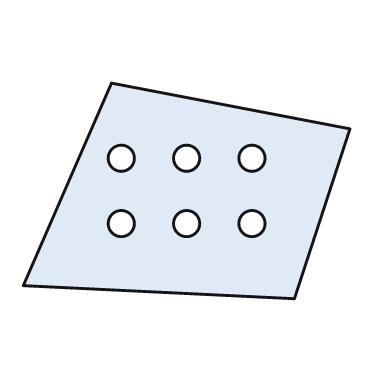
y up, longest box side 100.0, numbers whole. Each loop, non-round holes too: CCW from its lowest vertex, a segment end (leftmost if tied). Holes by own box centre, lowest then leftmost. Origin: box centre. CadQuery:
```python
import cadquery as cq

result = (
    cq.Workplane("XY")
    .moveTo(33.0, -33.0)
    .lineTo(50.0, 19.0)
    .lineTo(-23.0, 33.0)
    .lineTo(-50.0, -29.0)
    .close()
    .moveTo(-20.0, -10.0)
    .circle(4.0)
    .moveTo(0.0, -10.0)
    .circle(4.0)
    .moveTo(20.0, -10.0)
    .circle(4.0)
    .moveTo(-20.0, 10.0)
    .circle(4.0)
    .moveTo(0.0, 10.0)
    .circle(4.0)
    .moveTo(20.0, 10.0)
    .circle(4.0)
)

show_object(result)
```